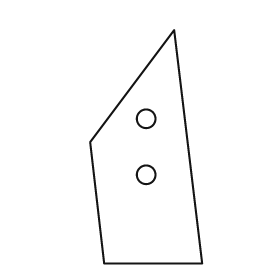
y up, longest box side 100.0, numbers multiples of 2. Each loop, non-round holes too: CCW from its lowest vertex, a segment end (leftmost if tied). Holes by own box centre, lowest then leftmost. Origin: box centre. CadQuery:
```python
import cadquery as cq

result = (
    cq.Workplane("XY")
    .moveTo(-18.0, -50.0)
    .lineTo(24.0, -50.0)
    .lineTo(12.0, 50.0)
    .lineTo(-24.0, 2.0)
    .close()
    .moveTo(0.0, -12.0)
    .circle(4.0)
    .moveTo(0.0, 12.0)
    .circle(4.0)
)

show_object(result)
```